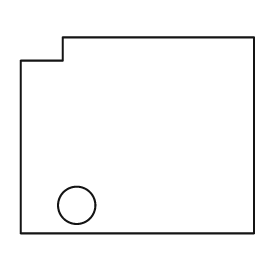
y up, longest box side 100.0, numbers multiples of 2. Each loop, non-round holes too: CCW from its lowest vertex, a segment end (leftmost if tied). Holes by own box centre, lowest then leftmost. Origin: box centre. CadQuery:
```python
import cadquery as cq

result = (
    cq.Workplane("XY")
    .moveTo(-50.0, -42.0)
    .lineTo(50.0, -42.0)
    .lineTo(50.0, 42.0)
    .lineTo(-32.0, 42.0)
    .lineTo(-32.0, 32.0)
    .lineTo(-50.0, 32.0)
    .close()
    .moveTo(-26.0, -30.0)
    .circle(8.0)
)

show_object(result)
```